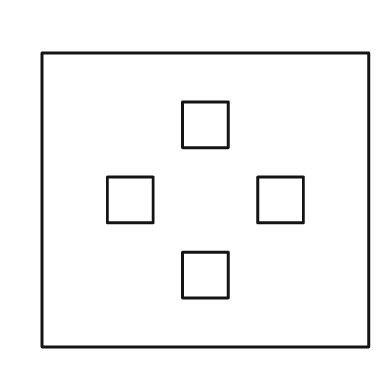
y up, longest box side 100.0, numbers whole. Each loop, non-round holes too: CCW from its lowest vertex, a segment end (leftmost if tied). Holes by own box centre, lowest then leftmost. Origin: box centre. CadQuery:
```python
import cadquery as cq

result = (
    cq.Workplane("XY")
    .moveTo(-50.0, -45.0)
    .lineTo(50.0, -45.0)
    .lineTo(50.0, 45.0)
    .lineTo(-50.0, 45.0)
    .close()
    .moveTo(-7.0, -30.0)
    .lineTo(7.0, -30.0)
    .lineTo(7.0, -16.0)
    .lineTo(-7.0, -16.0)
    .close()
    .moveTo(-30.0, -7.0)
    .lineTo(-16.0, -7.0)
    .lineTo(-16.0, 7.0)
    .lineTo(-30.0, 7.0)
    .close()
    .moveTo(16.0, -7.0)
    .lineTo(30.0, -7.0)
    .lineTo(30.0, 7.0)
    .lineTo(16.0, 7.0)
    .close()
    .moveTo(-7.0, 16.0)
    .lineTo(7.0, 16.0)
    .lineTo(7.0, 30.0)
    .lineTo(-7.0, 30.0)
    .close()
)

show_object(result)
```